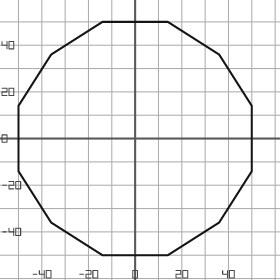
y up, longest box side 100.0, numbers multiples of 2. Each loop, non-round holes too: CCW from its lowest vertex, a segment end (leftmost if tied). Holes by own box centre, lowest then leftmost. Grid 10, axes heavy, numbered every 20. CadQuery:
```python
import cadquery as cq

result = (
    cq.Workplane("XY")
    .moveTo(-14.0, -50.0)
    .lineTo(14.0, -50.0)
    .lineTo(36.0, -36.0)
    .lineTo(50.0, -14.0)
    .lineTo(50.0, 14.0)
    .lineTo(36.0, 36.0)
    .lineTo(14.0, 50.0)
    .lineTo(-14.0, 50.0)
    .lineTo(-36.0, 36.0)
    .lineTo(-50.0, 14.0)
    .lineTo(-50.0, -14.0)
    .lineTo(-36.0, -36.0)
    .close()
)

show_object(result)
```